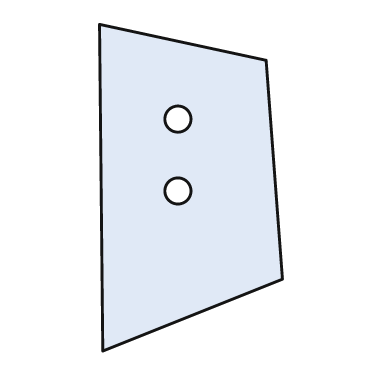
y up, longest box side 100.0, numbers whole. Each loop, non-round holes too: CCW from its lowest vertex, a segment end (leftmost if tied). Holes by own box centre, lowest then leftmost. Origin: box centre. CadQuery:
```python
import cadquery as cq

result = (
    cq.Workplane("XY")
    .moveTo(-27.0, -50.0)
    .lineTo(28.0, -28.0)
    .lineTo(23.0, 39.0)
    .lineTo(-28.0, 50.0)
    .close()
    .moveTo(-4.0, -1.0)
    .circle(4.0)
    .moveTo(-4.0, 21.0)
    .circle(4.0)
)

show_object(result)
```